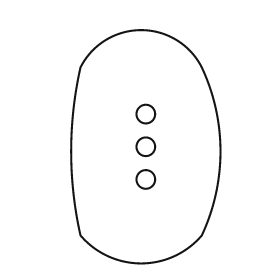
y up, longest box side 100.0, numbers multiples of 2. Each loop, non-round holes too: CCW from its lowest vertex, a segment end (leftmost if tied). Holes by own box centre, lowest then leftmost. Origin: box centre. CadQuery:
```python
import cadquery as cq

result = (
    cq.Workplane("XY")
    .moveTo(-28.0, -38.0)
    .threePointArc((-2.0, -50.0), (24.0, -38.0))
    .threePointArc((32.0, -2.0), (24.0, 34.0))
    .threePointArc((-2.0, 50.0), (-28.0, 34.0))
    .threePointArc((-32.0, -2.0), (-28.0, -38.0))
    .close()
    .moveTo(0.0, -14.0)
    .circle(4.0)
    .moveTo(0.0, 0.0)
    .circle(4.0)
    .moveTo(0.0, 14.0)
    .circle(4.0)
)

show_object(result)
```